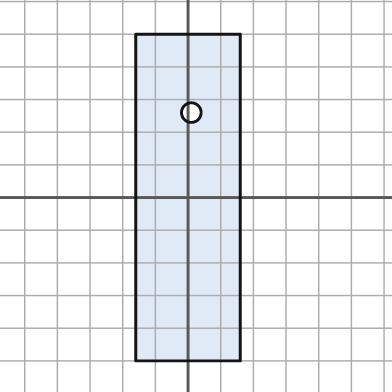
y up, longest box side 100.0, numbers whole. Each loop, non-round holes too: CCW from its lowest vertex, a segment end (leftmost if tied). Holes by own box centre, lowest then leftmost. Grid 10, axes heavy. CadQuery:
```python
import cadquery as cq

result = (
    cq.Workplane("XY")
    .moveTo(-16.0, -50.0)
    .lineTo(16.0, -50.0)
    .lineTo(16.0, 50.0)
    .lineTo(-16.0, 50.0)
    .close()
    .moveTo(1.0, 26.0)
    .circle(3.0)
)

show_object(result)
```